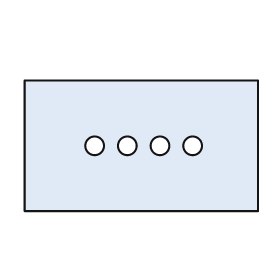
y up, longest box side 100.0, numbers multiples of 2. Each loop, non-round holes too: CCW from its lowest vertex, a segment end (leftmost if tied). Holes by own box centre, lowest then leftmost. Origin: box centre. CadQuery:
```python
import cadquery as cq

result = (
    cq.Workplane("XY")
    .moveTo(-50.0, -28.0)
    .lineTo(50.0, -28.0)
    .lineTo(50.0, 28.0)
    .lineTo(-50.0, 28.0)
    .close()
    .moveTo(-20.0, 0.0)
    .circle(4.0)
    .moveTo(-6.0, 0.0)
    .circle(4.0)
    .moveTo(8.0, 0.0)
    .circle(4.0)
    .moveTo(22.0, 0.0)
    .circle(4.0)
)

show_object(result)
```